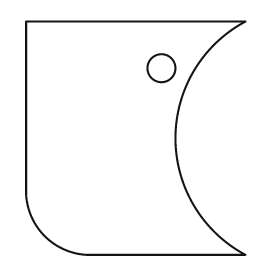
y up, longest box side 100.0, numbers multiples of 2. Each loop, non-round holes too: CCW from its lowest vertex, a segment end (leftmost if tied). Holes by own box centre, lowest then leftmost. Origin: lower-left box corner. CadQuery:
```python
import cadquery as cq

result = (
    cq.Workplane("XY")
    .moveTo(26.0, 0.0)
    .lineTo(94.0, 0.0)
    .threePointArc((64.0, 50.0), (94.0, 100.0))
    .lineTo(0.0, 100.0)
    .lineTo(0.0, 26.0)
    .threePointArc((8.0, 8.0), (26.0, 0.0))
    .close()
    .moveTo(58.0, 80.0)
    .circle(6.0)
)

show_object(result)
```